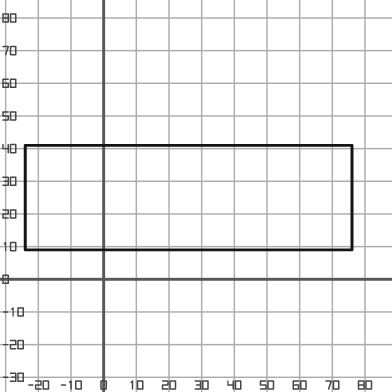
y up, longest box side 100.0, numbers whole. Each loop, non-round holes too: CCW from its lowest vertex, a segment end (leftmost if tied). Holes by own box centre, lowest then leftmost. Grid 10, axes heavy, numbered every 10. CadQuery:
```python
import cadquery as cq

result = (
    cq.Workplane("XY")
    .moveTo(-24.0, 9.0)
    .lineTo(76.0, 9.0)
    .lineTo(76.0, 41.0)
    .lineTo(-24.0, 41.0)
    .close()
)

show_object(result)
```